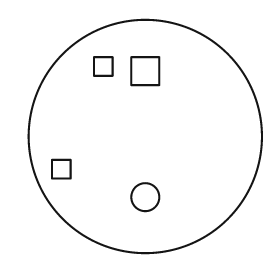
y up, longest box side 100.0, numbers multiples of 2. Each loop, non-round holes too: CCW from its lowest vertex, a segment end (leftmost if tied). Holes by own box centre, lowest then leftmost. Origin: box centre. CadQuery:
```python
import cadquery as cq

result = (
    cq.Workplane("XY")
    .moveTo(0.0, 0.0)
    .circle(50.0)
    .moveTo(0.0, -26.0)
    .circle(6.0)
    .moveTo(-40.0, -18.0)
    .lineTo(-32.0, -18.0)
    .lineTo(-32.0, -10.0)
    .lineTo(-40.0, -10.0)
    .close()
    .moveTo(-6.0, 22.0)
    .lineTo(6.0, 22.0)
    .lineTo(6.0, 34.0)
    .lineTo(-6.0, 34.0)
    .close()
    .moveTo(-22.0, 26.0)
    .lineTo(-14.0, 26.0)
    .lineTo(-14.0, 34.0)
    .lineTo(-22.0, 34.0)
    .close()
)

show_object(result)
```